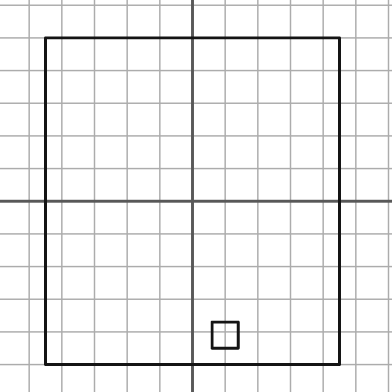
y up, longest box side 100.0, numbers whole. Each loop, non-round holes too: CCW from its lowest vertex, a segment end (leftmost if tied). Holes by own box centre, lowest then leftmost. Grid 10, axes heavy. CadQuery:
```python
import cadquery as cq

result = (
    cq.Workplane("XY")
    .moveTo(-45.0, -50.0)
    .lineTo(45.0, -50.0)
    .lineTo(45.0, 50.0)
    .lineTo(-45.0, 50.0)
    .close()
    .moveTo(6.0, -45.0)
    .lineTo(14.0, -45.0)
    .lineTo(14.0, -37.0)
    .lineTo(6.0, -37.0)
    .close()
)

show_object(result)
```